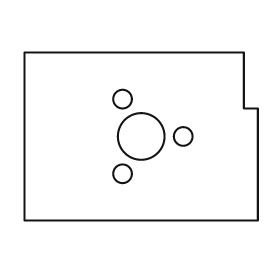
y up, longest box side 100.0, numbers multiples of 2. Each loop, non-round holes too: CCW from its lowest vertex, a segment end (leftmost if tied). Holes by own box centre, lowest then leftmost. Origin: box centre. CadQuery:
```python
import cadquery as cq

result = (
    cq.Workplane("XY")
    .moveTo(-50.0, -36.0)
    .lineTo(50.0, -36.0)
    .lineTo(50.0, 12.0)
    .lineTo(44.0, 12.0)
    .lineTo(44.0, 36.0)
    .lineTo(-50.0, 36.0)
    .close()
    .moveTo(-8.0, -16.0)
    .circle(4.0)
    .moveTo(0.0, 0.0)
    .circle(10.0)
    .moveTo(18.0, 0.0)
    .circle(4.0)
    .moveTo(-8.0, 16.0)
    .circle(4.0)
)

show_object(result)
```